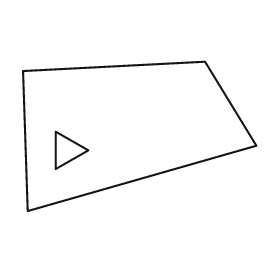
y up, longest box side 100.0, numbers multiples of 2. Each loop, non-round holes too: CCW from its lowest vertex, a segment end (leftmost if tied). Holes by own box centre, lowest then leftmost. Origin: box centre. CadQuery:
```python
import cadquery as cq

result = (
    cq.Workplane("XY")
    .moveTo(-48.0, -32.0)
    .lineTo(50.0, -4.0)
    .lineTo(28.0, 32.0)
    .lineTo(-50.0, 28.0)
    .close()
    .moveTo(-36.0, -14.0)
    .lineTo(-22.0, -6.0)
    .lineTo(-36.0, 2.0)
    .close()
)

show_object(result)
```